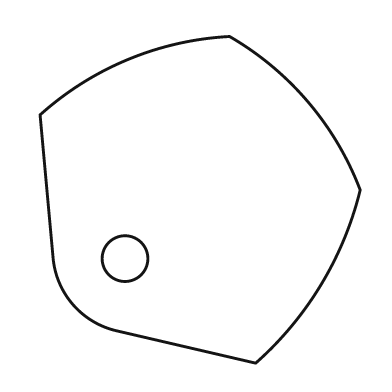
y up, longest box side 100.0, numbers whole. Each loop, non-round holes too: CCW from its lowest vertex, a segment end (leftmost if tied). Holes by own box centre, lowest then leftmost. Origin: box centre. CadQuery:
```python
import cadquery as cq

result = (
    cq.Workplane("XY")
    .moveTo(17.0, -50.0)
    .threePointArc((37.0, -26.0), (49.0, 3.0))
    .threePointArc((33.0, 30.0), (9.0, 50.0))
    .threePointArc((-22.0, 43.0), (-49.0, 26.0))
    .lineTo(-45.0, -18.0)
    .threePointArc((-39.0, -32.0), (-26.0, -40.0))
    .close()
    .moveTo(-23.0, -18.0)
    .circle(7.0)
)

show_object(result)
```